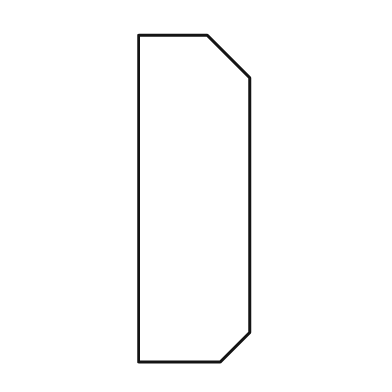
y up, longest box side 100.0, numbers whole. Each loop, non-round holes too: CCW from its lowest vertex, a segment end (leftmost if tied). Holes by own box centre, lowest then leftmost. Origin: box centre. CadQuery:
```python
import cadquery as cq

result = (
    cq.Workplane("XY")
    .moveTo(-17.0, -50.0)
    .lineTo(8.0, -50.0)
    .lineTo(17.0, -41.0)
    .lineTo(17.0, 37.0)
    .lineTo(4.0, 50.0)
    .lineTo(-17.0, 50.0)
    .close()
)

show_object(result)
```